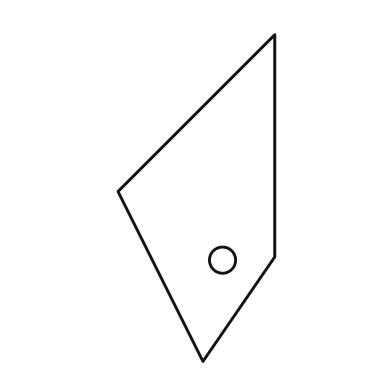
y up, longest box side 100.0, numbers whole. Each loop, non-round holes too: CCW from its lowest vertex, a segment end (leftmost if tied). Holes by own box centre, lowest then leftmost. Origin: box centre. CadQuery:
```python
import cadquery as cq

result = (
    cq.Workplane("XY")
    .moveTo(2.0, -50.0)
    .lineTo(24.0, -18.0)
    .lineTo(24.0, 50.0)
    .lineTo(-24.0, 2.0)
    .close()
    .moveTo(8.0, -19.0)
    .circle(4.0)
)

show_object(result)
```